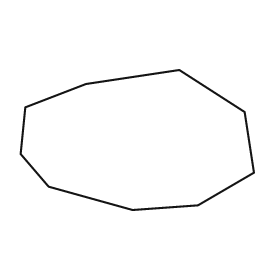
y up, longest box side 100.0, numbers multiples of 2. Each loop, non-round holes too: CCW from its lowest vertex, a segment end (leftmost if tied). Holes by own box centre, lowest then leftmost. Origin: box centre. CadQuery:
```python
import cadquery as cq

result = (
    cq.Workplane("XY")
    .moveTo(-2.0, -30.0)
    .lineTo(26.0, -28.0)
    .lineTo(50.0, -14.0)
    .lineTo(46.0, 12.0)
    .lineTo(18.0, 30.0)
    .lineTo(-22.0, 24.0)
    .lineTo(-48.0, 14.0)
    .lineTo(-50.0, -6.0)
    .lineTo(-38.0, -20.0)
    .close()
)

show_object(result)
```